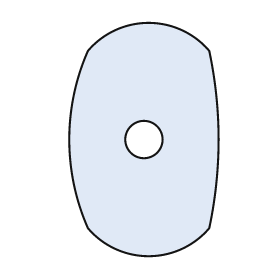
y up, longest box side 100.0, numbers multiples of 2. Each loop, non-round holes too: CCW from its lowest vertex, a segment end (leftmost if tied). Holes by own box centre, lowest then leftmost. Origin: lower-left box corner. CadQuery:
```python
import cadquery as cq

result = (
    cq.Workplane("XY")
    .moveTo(8.0, 12.0)
    .threePointArc((34.0, 0.0), (60.0, 12.0))
    .threePointArc((64.0, 50.0), (60.0, 88.0))
    .threePointArc((34.0, 100.0), (8.0, 88.0))
    .threePointArc((0.0, 50.0), (8.0, 12.0))
    .close()
    .moveTo(32.0, 50.0)
    .circle(8.0)
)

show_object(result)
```